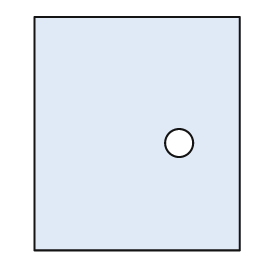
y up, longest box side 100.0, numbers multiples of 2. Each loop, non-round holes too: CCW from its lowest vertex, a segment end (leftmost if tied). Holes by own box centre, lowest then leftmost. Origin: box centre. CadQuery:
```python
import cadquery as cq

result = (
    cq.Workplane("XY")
    .moveTo(-44.0, -50.0)
    .lineTo(44.0, -50.0)
    .lineTo(44.0, 50.0)
    .lineTo(-44.0, 50.0)
    .close()
    .moveTo(18.0, -4.0)
    .circle(6.0)
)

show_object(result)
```